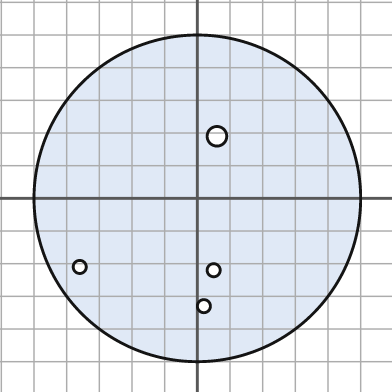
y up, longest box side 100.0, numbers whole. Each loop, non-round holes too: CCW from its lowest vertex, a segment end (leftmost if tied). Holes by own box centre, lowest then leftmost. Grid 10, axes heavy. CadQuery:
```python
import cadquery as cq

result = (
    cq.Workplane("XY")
    .moveTo(0.0, 0.0)
    .circle(50.0)
    .moveTo(2.0, -33.0)
    .circle(2.0)
    .moveTo(5.0, -22.0)
    .circle(2.0)
    .moveTo(-36.0, -21.0)
    .circle(2.0)
    .moveTo(6.0, 19.0)
    .circle(3.0)
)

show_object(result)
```